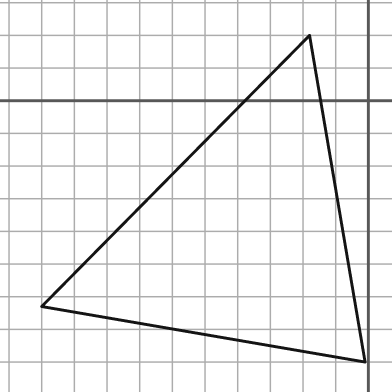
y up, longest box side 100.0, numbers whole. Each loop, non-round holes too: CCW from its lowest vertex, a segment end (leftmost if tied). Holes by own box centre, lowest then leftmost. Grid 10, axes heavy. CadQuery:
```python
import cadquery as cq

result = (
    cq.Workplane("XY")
    .moveTo(-1.0, -80.0)
    .lineTo(-18.0, 20.0)
    .lineTo(-100.0, -63.0)
    .close()
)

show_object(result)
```